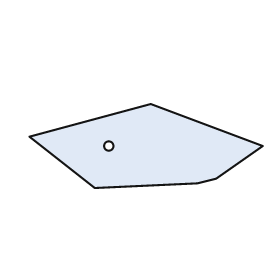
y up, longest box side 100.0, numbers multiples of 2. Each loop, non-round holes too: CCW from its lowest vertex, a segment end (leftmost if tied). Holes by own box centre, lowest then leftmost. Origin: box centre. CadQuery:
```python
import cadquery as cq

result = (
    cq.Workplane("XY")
    .moveTo(-22.0, -18.0)
    .lineTo(22.0, -16.0)
    .lineTo(30.0, -14.0)
    .lineTo(50.0, 0.0)
    .lineTo(2.0, 18.0)
    .lineTo(-50.0, 4.0)
    .close()
    .moveTo(-16.0, 0.0)
    .circle(2.0)
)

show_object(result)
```